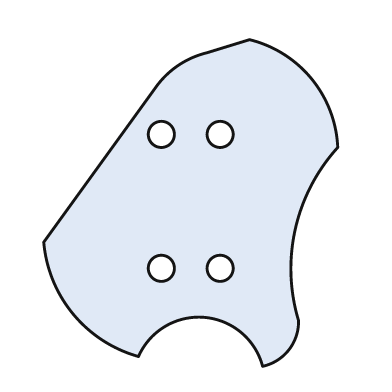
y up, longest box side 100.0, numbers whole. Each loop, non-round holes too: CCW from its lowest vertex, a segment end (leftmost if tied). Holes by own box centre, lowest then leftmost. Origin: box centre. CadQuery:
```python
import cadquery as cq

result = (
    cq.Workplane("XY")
    .moveTo(22.0, -50.0)
    .threePointArc((30.0, -45.0), (33.0, -36.0))
    .threePointArc((32.0, -8.0), (45.0, 17.0))
    .threePointArc((37.0, 38.0), (18.0, 50.0))
    .lineTo(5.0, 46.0)
    .threePointArc((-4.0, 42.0), (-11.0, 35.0))
    .lineTo(-45.0, -12.0)
    .threePointArc((-36.0, -34.0), (-16.0, -47.0))
    .threePointArc((4.0, -35.0), (22.0, -50.0))
    .close()
    .moveTo(-9.0, -20.0)
    .circle(4.0)
    .moveTo(9.0, -20.0)
    .circle(4.0)
    .moveTo(-9.0, 21.0)
    .circle(4.0)
    .moveTo(9.0, 21.0)
    .circle(4.0)
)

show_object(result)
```